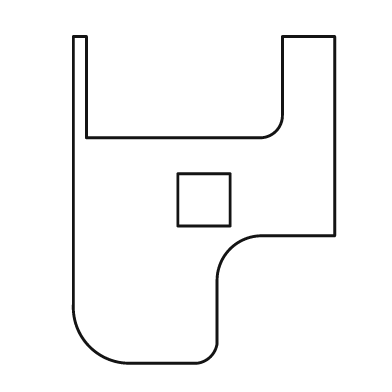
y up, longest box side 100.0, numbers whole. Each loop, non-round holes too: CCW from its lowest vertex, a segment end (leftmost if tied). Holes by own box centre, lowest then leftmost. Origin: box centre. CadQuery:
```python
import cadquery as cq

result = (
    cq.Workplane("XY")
    .moveTo(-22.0, -50.0)
    .lineTo(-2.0, -50.0)
    .threePointArc((2.0, -48.0), (4.0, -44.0))
    .lineTo(4.0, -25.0)
    .threePointArc((8.0, -15.0), (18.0, -11.0))
    .lineTo(40.0, -11.0)
    .lineTo(40.0, 50.0)
    .lineTo(24.0, 50.0)
    .lineTo(24.0, 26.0)
    .threePointArc((22.0, 21.0), (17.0, 19.0))
    .lineTo(-36.0, 19.0)
    .lineTo(-36.0, 50.0)
    .lineTo(-40.0, 50.0)
    .lineTo(-40.0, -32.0)
    .threePointArc((-35.0, -45.0), (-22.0, -50.0))
    .close()
    .moveTo(-8.0, -8.0)
    .lineTo(8.0, -8.0)
    .lineTo(8.0, 8.0)
    .lineTo(-8.0, 8.0)
    .close()
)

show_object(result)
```